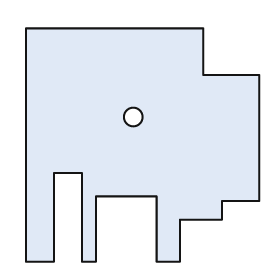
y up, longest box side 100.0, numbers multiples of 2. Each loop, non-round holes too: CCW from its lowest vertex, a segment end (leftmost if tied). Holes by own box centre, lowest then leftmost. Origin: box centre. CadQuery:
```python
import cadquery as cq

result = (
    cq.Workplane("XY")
    .moveTo(-50.0, -50.0)
    .lineTo(-38.0, -50.0)
    .lineTo(-38.0, -12.0)
    .lineTo(-26.0, -12.0)
    .lineTo(-26.0, -50.0)
    .lineTo(-20.0, -50.0)
    .lineTo(-20.0, -22.0)
    .lineTo(6.0, -22.0)
    .lineTo(6.0, -50.0)
    .lineTo(16.0, -50.0)
    .lineTo(16.0, -32.0)
    .lineTo(34.0, -32.0)
    .lineTo(34.0, -24.0)
    .lineTo(50.0, -24.0)
    .lineTo(50.0, 30.0)
    .lineTo(26.0, 30.0)
    .lineTo(26.0, 50.0)
    .lineTo(-50.0, 50.0)
    .close()
    .moveTo(-4.0, 12.0)
    .circle(4.0)
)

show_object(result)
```